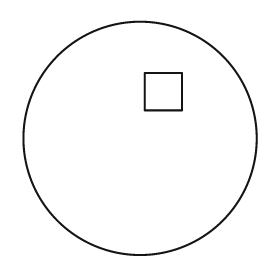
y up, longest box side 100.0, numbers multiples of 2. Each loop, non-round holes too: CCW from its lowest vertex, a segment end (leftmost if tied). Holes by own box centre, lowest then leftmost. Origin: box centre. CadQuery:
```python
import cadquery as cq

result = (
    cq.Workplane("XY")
    .moveTo(0.0, 0.0)
    .circle(50.0)
    .moveTo(2.0, 12.0)
    .lineTo(18.0, 12.0)
    .lineTo(18.0, 28.0)
    .lineTo(2.0, 28.0)
    .close()
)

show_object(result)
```